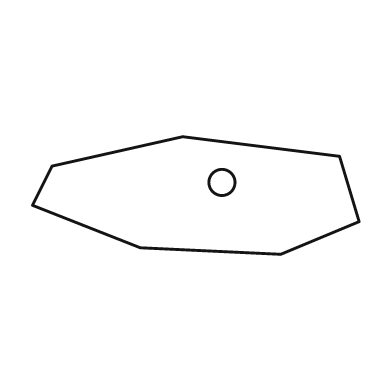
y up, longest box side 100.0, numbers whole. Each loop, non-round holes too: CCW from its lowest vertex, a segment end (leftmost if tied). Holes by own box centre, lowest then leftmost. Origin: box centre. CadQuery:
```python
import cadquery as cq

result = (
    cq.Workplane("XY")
    .moveTo(26.0, -18.0)
    .lineTo(50.0, -8.0)
    .lineTo(44.0, 12.0)
    .lineTo(-4.0, 18.0)
    .lineTo(-44.0, 9.0)
    .lineTo(-50.0, -3.0)
    .lineTo(-17.0, -16.0)
    .close()
    .moveTo(8.0, 4.0)
    .circle(4.0)
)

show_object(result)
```